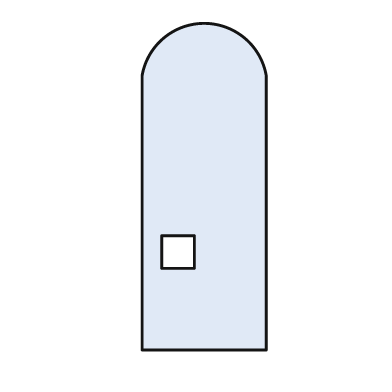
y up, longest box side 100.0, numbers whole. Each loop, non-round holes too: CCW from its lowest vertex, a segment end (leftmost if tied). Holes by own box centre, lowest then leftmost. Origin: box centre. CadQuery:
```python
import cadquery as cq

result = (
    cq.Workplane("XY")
    .moveTo(-19.0, -50.0)
    .lineTo(19.0, -50.0)
    .lineTo(19.0, 34.0)
    .threePointArc((0.0, 50.0), (-19.0, 34.0))
    .close()
    .moveTo(-13.0, -25.0)
    .lineTo(-3.0, -25.0)
    .lineTo(-3.0, -15.0)
    .lineTo(-13.0, -15.0)
    .close()
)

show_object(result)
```